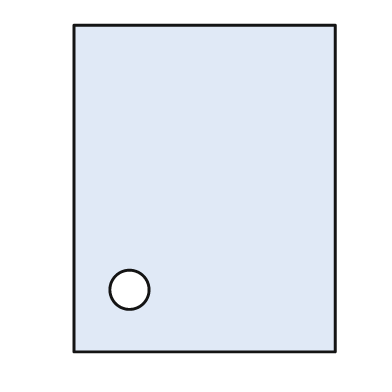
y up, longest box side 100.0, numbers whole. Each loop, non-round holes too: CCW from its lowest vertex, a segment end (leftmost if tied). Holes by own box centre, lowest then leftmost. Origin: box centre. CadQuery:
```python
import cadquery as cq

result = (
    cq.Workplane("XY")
    .moveTo(-40.0, -50.0)
    .lineTo(40.0, -50.0)
    .lineTo(40.0, 50.0)
    .lineTo(-40.0, 50.0)
    .close()
    .moveTo(-23.0, -31.0)
    .circle(6.0)
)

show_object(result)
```